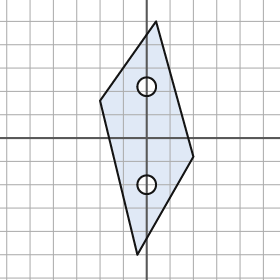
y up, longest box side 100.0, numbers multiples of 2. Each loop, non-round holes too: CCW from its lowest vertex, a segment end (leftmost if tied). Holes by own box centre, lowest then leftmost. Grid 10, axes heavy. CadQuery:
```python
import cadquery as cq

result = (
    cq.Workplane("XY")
    .moveTo(-4.0, -50.0)
    .lineTo(20.0, -8.0)
    .lineTo(4.0, 50.0)
    .lineTo(-20.0, 16.0)
    .close()
    .moveTo(0.0, -20.0)
    .circle(4.0)
    .moveTo(0.0, 22.0)
    .circle(4.0)
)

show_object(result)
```